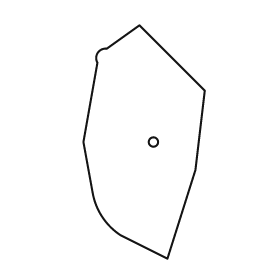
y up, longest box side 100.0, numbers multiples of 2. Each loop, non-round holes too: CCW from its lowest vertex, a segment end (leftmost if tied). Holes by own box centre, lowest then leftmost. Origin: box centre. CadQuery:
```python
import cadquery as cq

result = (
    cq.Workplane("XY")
    .moveTo(10.0, -50.0)
    .lineTo(22.0, -12.0)
    .lineTo(26.0, 22.0)
    .lineTo(-2.0, 50.0)
    .lineTo(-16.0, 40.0)
    .threePointArc((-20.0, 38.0), (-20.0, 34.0))
    .lineTo(-26.0, 0.0)
    .lineTo(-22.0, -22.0)
    .threePointArc((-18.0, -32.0), (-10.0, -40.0))
    .close()
    .moveTo(4.0, 0.0)
    .circle(2.0)
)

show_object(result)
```